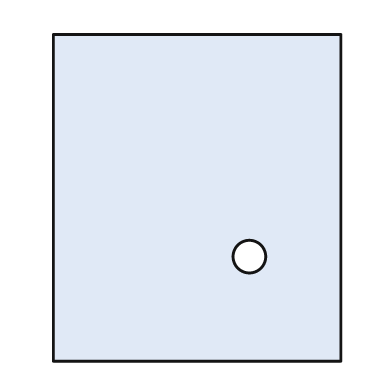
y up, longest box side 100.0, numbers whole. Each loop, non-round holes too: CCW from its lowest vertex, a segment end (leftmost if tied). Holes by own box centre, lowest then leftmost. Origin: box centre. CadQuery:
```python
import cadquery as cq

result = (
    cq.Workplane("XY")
    .moveTo(-44.0, -50.0)
    .lineTo(44.0, -50.0)
    .lineTo(44.0, 50.0)
    .lineTo(-44.0, 50.0)
    .close()
    .moveTo(16.0, -18.0)
    .circle(5.0)
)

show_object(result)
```